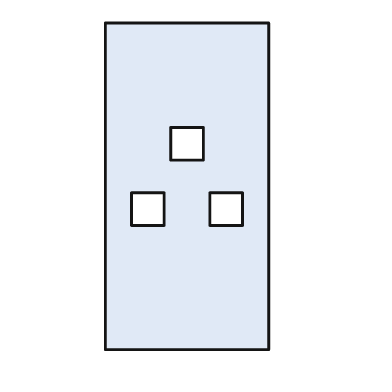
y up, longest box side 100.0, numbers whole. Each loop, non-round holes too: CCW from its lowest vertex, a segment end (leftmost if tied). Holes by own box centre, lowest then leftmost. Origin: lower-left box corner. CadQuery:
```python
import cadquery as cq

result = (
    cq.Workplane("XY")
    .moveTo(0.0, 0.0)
    .lineTo(50.0, 0.0)
    .lineTo(50.0, 100.0)
    .lineTo(0.0, 100.0)
    .close()
    .moveTo(8.0, 38.0)
    .lineTo(18.0, 38.0)
    .lineTo(18.0, 48.0)
    .lineTo(8.0, 48.0)
    .close()
    .moveTo(32.0, 38.0)
    .lineTo(42.0, 38.0)
    .lineTo(42.0, 48.0)
    .lineTo(32.0, 48.0)
    .close()
    .moveTo(20.0, 58.0)
    .lineTo(30.0, 58.0)
    .lineTo(30.0, 68.0)
    .lineTo(20.0, 68.0)
    .close()
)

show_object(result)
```